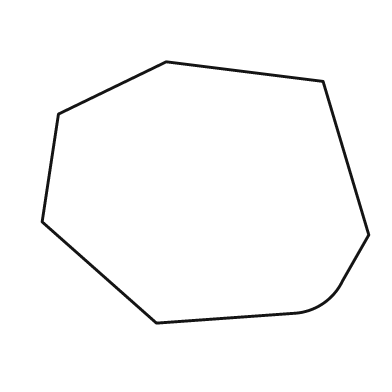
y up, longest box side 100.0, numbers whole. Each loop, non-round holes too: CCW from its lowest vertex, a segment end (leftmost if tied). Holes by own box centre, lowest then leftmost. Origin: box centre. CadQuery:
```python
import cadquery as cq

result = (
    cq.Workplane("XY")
    .moveTo(-15.0, -40.0)
    .lineTo(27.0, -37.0)
    .threePointArc((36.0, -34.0), (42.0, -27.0))
    .lineTo(50.0, -13.0)
    .lineTo(36.0, 34.0)
    .lineTo(-12.0, 40.0)
    .lineTo(-45.0, 24.0)
    .lineTo(-50.0, -9.0)
    .close()
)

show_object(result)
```